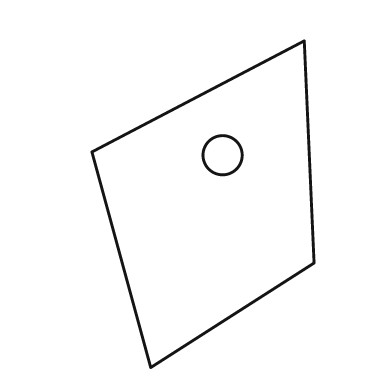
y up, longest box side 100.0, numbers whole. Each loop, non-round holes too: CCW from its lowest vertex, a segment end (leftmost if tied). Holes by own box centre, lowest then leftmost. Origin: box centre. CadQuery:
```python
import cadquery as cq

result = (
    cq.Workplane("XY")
    .moveTo(-16.0, -50.0)
    .lineTo(34.0, -18.0)
    .lineTo(31.0, 50.0)
    .lineTo(-34.0, 16.0)
    .close()
    .moveTo(6.0, 15.0)
    .circle(6.0)
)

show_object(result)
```